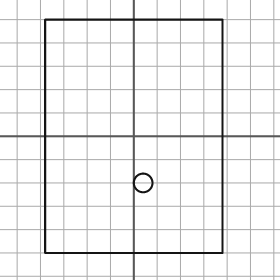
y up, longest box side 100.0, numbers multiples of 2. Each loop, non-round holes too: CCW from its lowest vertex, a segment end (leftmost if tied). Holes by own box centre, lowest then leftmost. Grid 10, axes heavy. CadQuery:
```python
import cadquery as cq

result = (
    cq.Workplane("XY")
    .moveTo(-38.0, -50.0)
    .lineTo(38.0, -50.0)
    .lineTo(38.0, 50.0)
    .lineTo(-38.0, 50.0)
    .close()
    .moveTo(4.0, -20.0)
    .circle(4.0)
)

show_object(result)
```